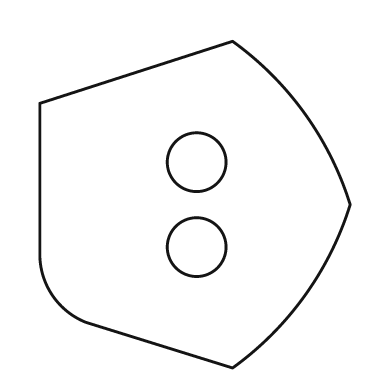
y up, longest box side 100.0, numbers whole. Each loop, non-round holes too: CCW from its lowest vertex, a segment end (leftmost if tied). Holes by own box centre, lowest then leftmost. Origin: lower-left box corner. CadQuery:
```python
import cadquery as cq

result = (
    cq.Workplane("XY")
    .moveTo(59.0, 0.0)
    .threePointArc((81.0, 22.0), (95.0, 50.0))
    .threePointArc((81.0, 78.0), (59.0, 100.0))
    .lineTo(0.0, 81.0)
    .lineTo(0.0, 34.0)
    .threePointArc((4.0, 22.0), (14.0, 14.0))
    .close()
    .moveTo(48.0, 37.0)
    .circle(9.0)
    .moveTo(48.0, 63.0)
    .circle(9.0)
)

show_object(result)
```